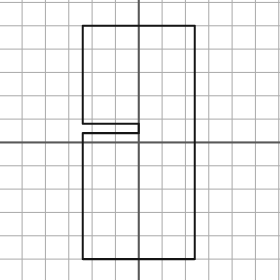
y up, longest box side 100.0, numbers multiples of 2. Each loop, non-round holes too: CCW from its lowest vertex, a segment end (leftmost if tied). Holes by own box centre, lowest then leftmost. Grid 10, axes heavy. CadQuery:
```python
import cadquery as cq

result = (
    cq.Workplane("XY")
    .moveTo(-24.0, -50.0)
    .lineTo(24.0, -50.0)
    .lineTo(24.0, 50.0)
    .lineTo(-24.0, 50.0)
    .lineTo(-24.0, 8.0)
    .lineTo(0.0, 8.0)
    .lineTo(0.0, 4.0)
    .lineTo(-24.0, 4.0)
    .close()
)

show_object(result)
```